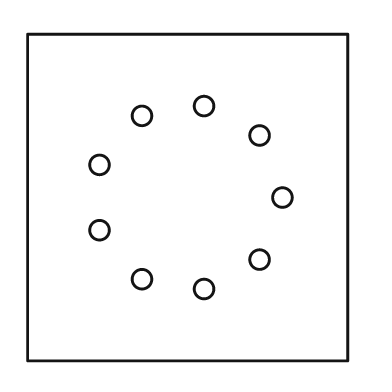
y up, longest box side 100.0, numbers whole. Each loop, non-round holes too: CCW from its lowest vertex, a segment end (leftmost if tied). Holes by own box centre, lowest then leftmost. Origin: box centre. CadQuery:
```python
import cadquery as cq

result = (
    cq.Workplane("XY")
    .moveTo(-49.0, -50.0)
    .lineTo(49.0, -50.0)
    .lineTo(49.0, 50.0)
    .lineTo(-49.0, 50.0)
    .close()
    .moveTo(5.0, -28.0)
    .circle(3.0)
    .moveTo(-14.0, -25.0)
    .circle(3.0)
    .moveTo(22.0, -19.0)
    .circle(3.0)
    .moveTo(-27.0, -10.0)
    .circle(3.0)
    .moveTo(29.0, 0.0)
    .circle(3.0)
    .moveTo(-27.0, 10.0)
    .circle(3.0)
    .moveTo(22.0, 19.0)
    .circle(3.0)
    .moveTo(-14.0, 25.0)
    .circle(3.0)
    .moveTo(5.0, 28.0)
    .circle(3.0)
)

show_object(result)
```